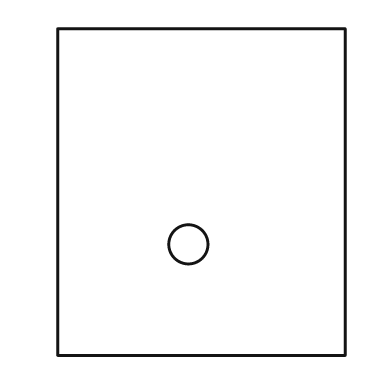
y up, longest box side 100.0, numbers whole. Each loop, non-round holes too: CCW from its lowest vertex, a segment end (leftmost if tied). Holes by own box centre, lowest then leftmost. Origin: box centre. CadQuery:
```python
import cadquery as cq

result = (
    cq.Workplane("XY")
    .moveTo(-44.0, -50.0)
    .lineTo(44.0, -50.0)
    .lineTo(44.0, 50.0)
    .lineTo(-44.0, 50.0)
    .close()
    .moveTo(-4.0, -16.0)
    .circle(6.0)
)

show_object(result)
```